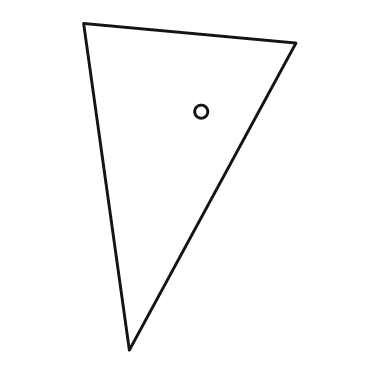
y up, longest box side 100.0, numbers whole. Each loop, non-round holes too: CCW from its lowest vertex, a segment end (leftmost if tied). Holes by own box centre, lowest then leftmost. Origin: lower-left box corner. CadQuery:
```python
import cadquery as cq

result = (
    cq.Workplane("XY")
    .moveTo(14.0, 0.0)
    .lineTo(65.0, 94.0)
    .lineTo(0.0, 100.0)
    .close()
    .moveTo(36.0, 73.0)
    .circle(2.0)
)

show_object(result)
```